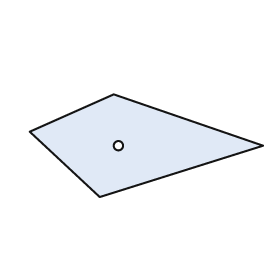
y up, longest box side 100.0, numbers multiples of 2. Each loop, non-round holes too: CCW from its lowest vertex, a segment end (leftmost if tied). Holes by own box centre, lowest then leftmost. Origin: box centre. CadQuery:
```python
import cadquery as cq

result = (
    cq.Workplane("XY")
    .moveTo(-20.0, -22.0)
    .lineTo(50.0, 0.0)
    .lineTo(-14.0, 22.0)
    .lineTo(-50.0, 6.0)
    .close()
    .moveTo(-12.0, 0.0)
    .circle(2.0)
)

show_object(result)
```